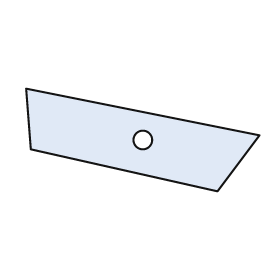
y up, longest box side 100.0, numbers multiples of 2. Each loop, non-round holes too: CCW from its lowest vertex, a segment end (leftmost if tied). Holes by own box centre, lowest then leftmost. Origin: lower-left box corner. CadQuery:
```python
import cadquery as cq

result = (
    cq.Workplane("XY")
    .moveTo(82.0, 0.0)
    .lineTo(100.0, 24.0)
    .lineTo(0.0, 44.0)
    .lineTo(2.0, 18.0)
    .close()
    .moveTo(50.0, 22.0)
    .circle(4.0)
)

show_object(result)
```